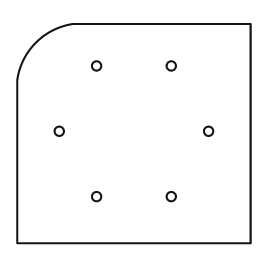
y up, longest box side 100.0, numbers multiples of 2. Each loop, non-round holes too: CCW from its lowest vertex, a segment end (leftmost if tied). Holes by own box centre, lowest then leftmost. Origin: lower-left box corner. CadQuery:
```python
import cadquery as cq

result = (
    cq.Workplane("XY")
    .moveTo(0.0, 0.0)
    .lineTo(100.0, 0.0)
    .lineTo(100.0, 94.0)
    .lineTo(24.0, 94.0)
    .threePointArc((8.0, 86.0), (0.0, 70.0))
    .close()
    .moveTo(34.0, 20.0)
    .circle(2.0)
    .moveTo(66.0, 20.0)
    .circle(2.0)
    .moveTo(18.0, 48.0)
    .circle(2.0)
    .moveTo(82.0, 48.0)
    .circle(2.0)
    .moveTo(34.0, 76.0)
    .circle(2.0)
    .moveTo(66.0, 76.0)
    .circle(2.0)
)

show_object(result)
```